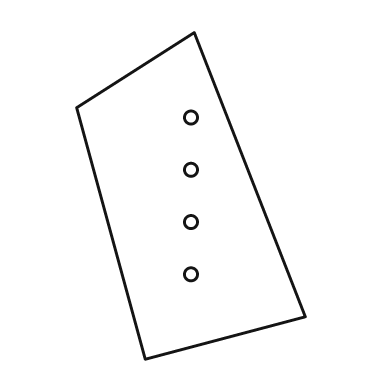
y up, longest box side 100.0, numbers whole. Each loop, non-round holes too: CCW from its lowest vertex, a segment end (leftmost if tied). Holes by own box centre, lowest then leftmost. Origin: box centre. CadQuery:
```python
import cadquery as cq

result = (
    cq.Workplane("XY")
    .moveTo(-14.0, -50.0)
    .lineTo(35.0, -37.0)
    .lineTo(1.0, 50.0)
    .lineTo(-35.0, 27.0)
    .close()
    .moveTo(0.0, -24.0)
    .circle(2.0)
    .moveTo(0.0, -8.0)
    .circle(2.0)
    .moveTo(0.0, 8.0)
    .circle(2.0)
    .moveTo(0.0, 24.0)
    .circle(2.0)
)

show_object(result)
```